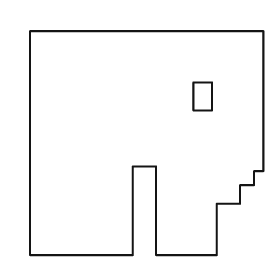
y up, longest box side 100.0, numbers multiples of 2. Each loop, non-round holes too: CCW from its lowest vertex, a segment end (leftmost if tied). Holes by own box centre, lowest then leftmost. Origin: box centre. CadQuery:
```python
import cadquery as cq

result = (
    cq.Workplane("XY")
    .moveTo(-50.0, -48.0)
    .lineTo(-6.0, -48.0)
    .lineTo(-6.0, -10.0)
    .lineTo(4.0, -10.0)
    .lineTo(4.0, -48.0)
    .lineTo(30.0, -48.0)
    .lineTo(30.0, -26.0)
    .lineTo(40.0, -26.0)
    .lineTo(40.0, -18.0)
    .lineTo(46.0, -18.0)
    .lineTo(46.0, -12.0)
    .lineTo(50.0, -12.0)
    .lineTo(50.0, 48.0)
    .lineTo(-50.0, 48.0)
    .close()
    .moveTo(20.0, 14.0)
    .lineTo(28.0, 14.0)
    .lineTo(28.0, 26.0)
    .lineTo(20.0, 26.0)
    .close()
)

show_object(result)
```